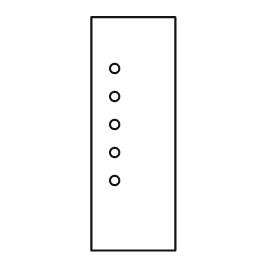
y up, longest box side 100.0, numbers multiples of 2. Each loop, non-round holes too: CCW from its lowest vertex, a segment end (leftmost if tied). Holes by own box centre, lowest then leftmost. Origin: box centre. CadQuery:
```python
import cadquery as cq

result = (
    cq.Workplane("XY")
    .moveTo(-18.0, -50.0)
    .lineTo(18.0, -50.0)
    .lineTo(18.0, 50.0)
    .lineTo(-18.0, 50.0)
    .close()
    .moveTo(-8.0, -20.0)
    .circle(2.0)
    .moveTo(-8.0, -8.0)
    .circle(2.0)
    .moveTo(-8.0, 4.0)
    .circle(2.0)
    .moveTo(-8.0, 16.0)
    .circle(2.0)
    .moveTo(-8.0, 28.0)
    .circle(2.0)
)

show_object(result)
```